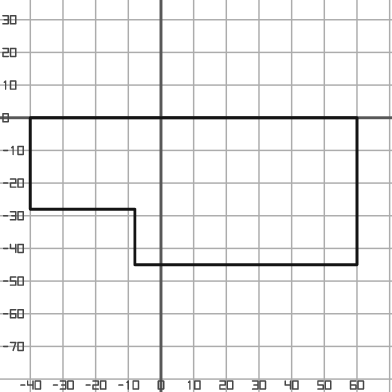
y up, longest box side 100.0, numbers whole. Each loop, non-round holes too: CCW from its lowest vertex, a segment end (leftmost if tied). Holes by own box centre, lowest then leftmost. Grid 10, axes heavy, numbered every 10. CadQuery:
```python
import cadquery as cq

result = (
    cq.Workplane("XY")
    .moveTo(-8.0, -45.0)
    .lineTo(60.0, -45.0)
    .lineTo(60.0, 0.0)
    .lineTo(-40.0, 0.0)
    .lineTo(-40.0, -28.0)
    .lineTo(-8.0, -28.0)
    .close()
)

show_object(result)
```